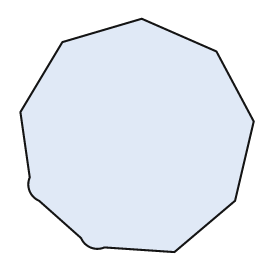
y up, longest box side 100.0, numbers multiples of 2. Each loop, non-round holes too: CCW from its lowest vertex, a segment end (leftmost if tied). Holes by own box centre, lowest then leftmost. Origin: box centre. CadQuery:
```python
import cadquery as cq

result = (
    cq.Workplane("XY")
    .moveTo(16.0, -50.0)
    .lineTo(42.0, -28.0)
    .lineTo(50.0, 6.0)
    .lineTo(34.0, 36.0)
    .lineTo(2.0, 50.0)
    .lineTo(-32.0, 40.0)
    .lineTo(-50.0, 10.0)
    .lineTo(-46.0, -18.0)
    .threePointArc((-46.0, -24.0), (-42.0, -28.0))
    .lineTo(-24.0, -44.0)
    .threePointArc((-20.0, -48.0), (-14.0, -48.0))
    .close()
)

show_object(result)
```